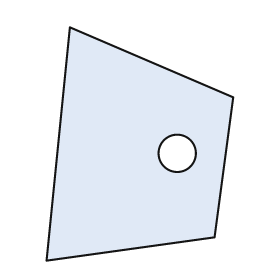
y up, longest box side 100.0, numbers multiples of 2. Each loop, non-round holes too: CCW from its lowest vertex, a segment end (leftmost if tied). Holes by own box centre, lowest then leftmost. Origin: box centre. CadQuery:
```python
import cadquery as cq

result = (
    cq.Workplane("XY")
    .moveTo(-40.0, -50.0)
    .lineTo(32.0, -40.0)
    .lineTo(40.0, 20.0)
    .lineTo(-30.0, 50.0)
    .close()
    .moveTo(16.0, -4.0)
    .circle(8.0)
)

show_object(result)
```